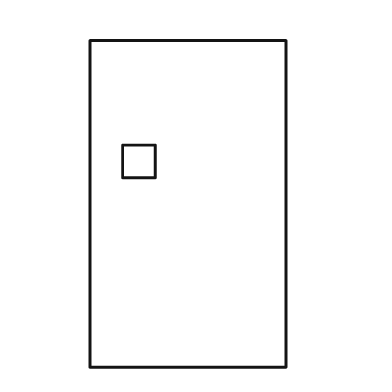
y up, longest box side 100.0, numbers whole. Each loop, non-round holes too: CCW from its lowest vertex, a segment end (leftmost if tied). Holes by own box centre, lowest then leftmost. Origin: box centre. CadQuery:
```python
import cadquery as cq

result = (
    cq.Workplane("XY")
    .moveTo(-30.0, -50.0)
    .lineTo(30.0, -50.0)
    .lineTo(30.0, 50.0)
    .lineTo(-30.0, 50.0)
    .close()
    .moveTo(-20.0, 8.0)
    .lineTo(-10.0, 8.0)
    .lineTo(-10.0, 18.0)
    .lineTo(-20.0, 18.0)
    .close()
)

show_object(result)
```